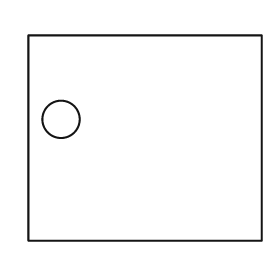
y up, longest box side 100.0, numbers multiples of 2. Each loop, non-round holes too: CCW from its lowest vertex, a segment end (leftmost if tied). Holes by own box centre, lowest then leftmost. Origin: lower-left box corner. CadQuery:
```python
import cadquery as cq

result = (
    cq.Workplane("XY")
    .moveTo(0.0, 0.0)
    .lineTo(100.0, 0.0)
    .lineTo(100.0, 88.0)
    .lineTo(0.0, 88.0)
    .close()
    .moveTo(14.0, 52.0)
    .circle(8.0)
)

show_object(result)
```